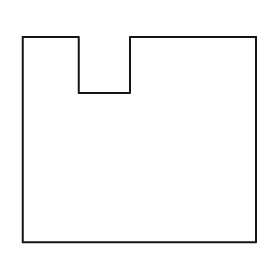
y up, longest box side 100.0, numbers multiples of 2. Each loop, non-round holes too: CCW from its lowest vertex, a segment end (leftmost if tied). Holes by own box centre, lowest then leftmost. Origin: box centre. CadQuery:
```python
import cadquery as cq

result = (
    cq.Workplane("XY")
    .moveTo(-50.0, -44.0)
    .lineTo(50.0, -44.0)
    .lineTo(50.0, 44.0)
    .lineTo(-4.0, 44.0)
    .lineTo(-4.0, 20.0)
    .lineTo(-26.0, 20.0)
    .lineTo(-26.0, 44.0)
    .lineTo(-50.0, 44.0)
    .close()
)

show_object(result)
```